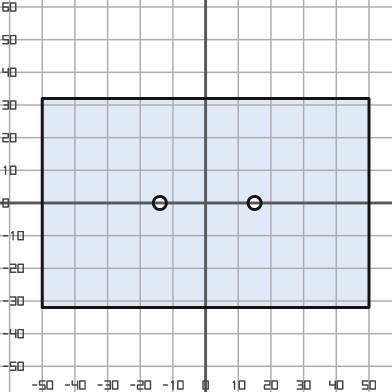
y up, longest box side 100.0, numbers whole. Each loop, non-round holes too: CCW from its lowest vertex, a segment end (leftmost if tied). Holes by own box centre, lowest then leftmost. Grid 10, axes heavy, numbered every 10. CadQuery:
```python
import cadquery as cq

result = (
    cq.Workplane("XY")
    .moveTo(-50.0, -32.0)
    .lineTo(50.0, -32.0)
    .lineTo(50.0, 32.0)
    .lineTo(-50.0, 32.0)
    .close()
    .moveTo(-14.0, 0.0)
    .circle(2.0)
    .moveTo(15.0, 0.0)
    .circle(2.0)
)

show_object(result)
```